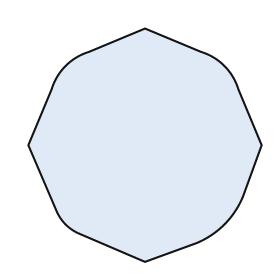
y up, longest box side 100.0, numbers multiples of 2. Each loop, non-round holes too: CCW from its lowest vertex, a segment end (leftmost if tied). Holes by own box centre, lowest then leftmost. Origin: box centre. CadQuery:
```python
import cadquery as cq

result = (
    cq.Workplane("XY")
    .moveTo(0.0, -50.0)
    .lineTo(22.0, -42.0)
    .threePointArc((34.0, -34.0), (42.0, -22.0))
    .lineTo(50.0, 0.0)
    .lineTo(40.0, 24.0)
    .threePointArc((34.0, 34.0), (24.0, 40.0))
    .lineTo(0.0, 50.0)
    .lineTo(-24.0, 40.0)
    .threePointArc((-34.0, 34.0), (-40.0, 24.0))
    .lineTo(-50.0, 0.0)
    .lineTo(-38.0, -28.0)
    .threePointArc((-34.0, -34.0), (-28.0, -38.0))
    .close()
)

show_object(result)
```